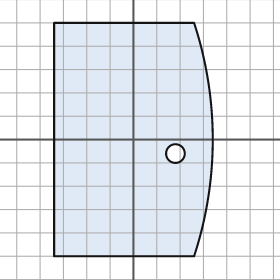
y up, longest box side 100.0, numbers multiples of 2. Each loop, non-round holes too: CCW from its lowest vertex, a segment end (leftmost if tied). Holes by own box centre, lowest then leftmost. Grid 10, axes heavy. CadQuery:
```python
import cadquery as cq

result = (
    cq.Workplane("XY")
    .moveTo(-34.0, -50.0)
    .lineTo(26.0, -50.0)
    .threePointArc((34.0, 0.0), (26.0, 50.0))
    .lineTo(-34.0, 50.0)
    .close()
    .moveTo(18.0, -6.0)
    .circle(4.0)
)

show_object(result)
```